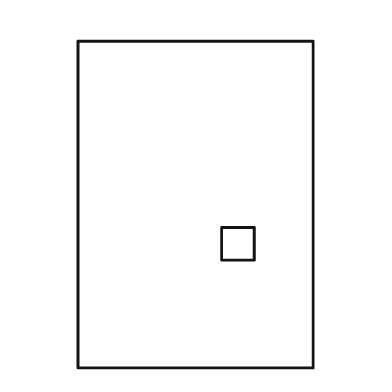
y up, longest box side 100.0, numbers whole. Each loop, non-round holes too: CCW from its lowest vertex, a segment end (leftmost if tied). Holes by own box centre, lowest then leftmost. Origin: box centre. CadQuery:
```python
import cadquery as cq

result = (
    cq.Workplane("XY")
    .moveTo(-36.0, -50.0)
    .lineTo(36.0, -50.0)
    .lineTo(36.0, 50.0)
    .lineTo(-36.0, 50.0)
    .close()
    .moveTo(8.0, -17.0)
    .lineTo(18.0, -17.0)
    .lineTo(18.0, -7.0)
    .lineTo(8.0, -7.0)
    .close()
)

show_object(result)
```